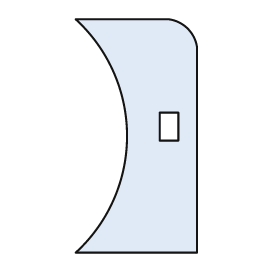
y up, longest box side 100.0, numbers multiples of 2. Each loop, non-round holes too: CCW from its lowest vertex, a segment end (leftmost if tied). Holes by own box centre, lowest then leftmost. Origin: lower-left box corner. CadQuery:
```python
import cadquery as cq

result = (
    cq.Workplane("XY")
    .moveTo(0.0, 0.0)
    .lineTo(52.0, 0.0)
    .lineTo(52.0, 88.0)
    .threePointArc((48.0, 96.0), (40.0, 100.0))
    .lineTo(0.0, 100.0)
    .threePointArc((22.0, 50.0), (0.0, 0.0))
    .close()
    .moveTo(36.0, 48.0)
    .lineTo(44.0, 48.0)
    .lineTo(44.0, 60.0)
    .lineTo(36.0, 60.0)
    .close()
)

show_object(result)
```